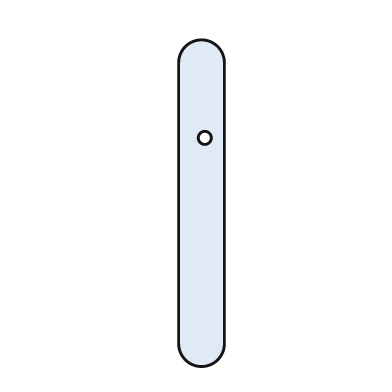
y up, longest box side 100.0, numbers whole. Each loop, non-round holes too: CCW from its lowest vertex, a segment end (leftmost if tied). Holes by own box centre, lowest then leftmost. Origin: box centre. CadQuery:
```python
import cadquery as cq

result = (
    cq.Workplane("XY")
    .moveTo(-7.0, -43.0)
    .threePointArc((0.0, -50.0), (7.0, -43.0))
    .lineTo(7.0, 43.0)
    .threePointArc((0.0, 50.0), (-7.0, 43.0))
    .close()
    .moveTo(1.0, 20.0)
    .circle(2.0)
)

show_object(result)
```